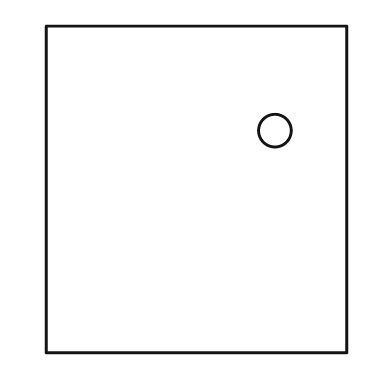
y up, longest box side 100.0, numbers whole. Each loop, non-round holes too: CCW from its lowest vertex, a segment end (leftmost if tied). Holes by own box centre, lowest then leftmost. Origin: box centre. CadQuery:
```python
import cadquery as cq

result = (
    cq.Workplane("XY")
    .moveTo(-46.0, -50.0)
    .lineTo(46.0, -50.0)
    .lineTo(46.0, 50.0)
    .lineTo(-46.0, 50.0)
    .close()
    .moveTo(24.0, 18.0)
    .circle(5.0)
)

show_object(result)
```